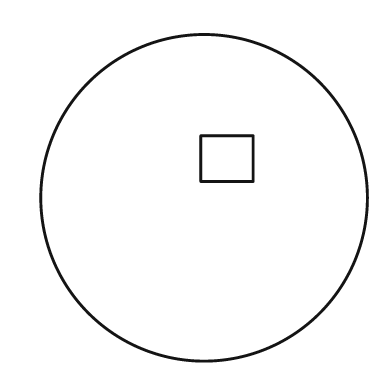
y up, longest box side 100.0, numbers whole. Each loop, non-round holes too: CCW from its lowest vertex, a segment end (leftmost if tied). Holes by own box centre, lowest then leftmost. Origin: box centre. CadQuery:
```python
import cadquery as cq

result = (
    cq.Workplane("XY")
    .moveTo(0.0, 0.0)
    .circle(50.0)
    .moveTo(-1.0, 5.0)
    .lineTo(15.0, 5.0)
    .lineTo(15.0, 19.0)
    .lineTo(-1.0, 19.0)
    .close()
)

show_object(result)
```